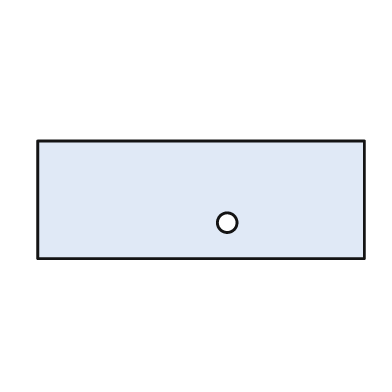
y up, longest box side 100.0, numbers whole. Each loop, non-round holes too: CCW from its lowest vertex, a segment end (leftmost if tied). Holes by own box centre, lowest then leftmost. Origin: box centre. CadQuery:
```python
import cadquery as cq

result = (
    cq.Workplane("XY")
    .moveTo(-50.0, -18.0)
    .lineTo(50.0, -18.0)
    .lineTo(50.0, 18.0)
    .lineTo(-50.0, 18.0)
    .close()
    .moveTo(8.0, -7.0)
    .circle(3.0)
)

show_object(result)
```